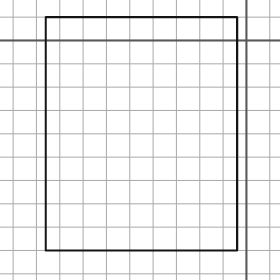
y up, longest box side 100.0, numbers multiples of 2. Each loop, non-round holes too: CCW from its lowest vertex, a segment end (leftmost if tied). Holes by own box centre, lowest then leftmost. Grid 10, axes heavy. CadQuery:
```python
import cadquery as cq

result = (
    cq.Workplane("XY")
    .moveTo(-86.0, -90.0)
    .lineTo(-4.0, -90.0)
    .lineTo(-4.0, 10.0)
    .lineTo(-86.0, 10.0)
    .close()
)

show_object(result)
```